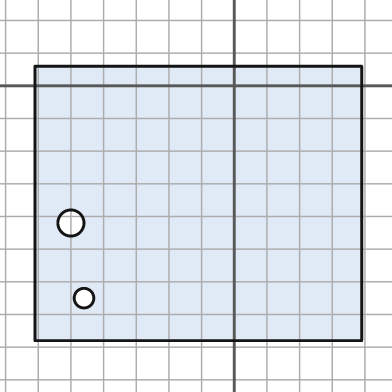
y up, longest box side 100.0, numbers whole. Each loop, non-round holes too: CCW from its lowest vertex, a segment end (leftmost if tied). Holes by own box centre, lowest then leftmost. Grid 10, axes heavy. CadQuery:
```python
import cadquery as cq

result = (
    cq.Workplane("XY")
    .moveTo(-61.0, -78.0)
    .lineTo(39.0, -78.0)
    .lineTo(39.0, 6.0)
    .lineTo(-61.0, 6.0)
    .close()
    .moveTo(-46.0, -65.0)
    .circle(3.0)
    .moveTo(-50.0, -42.0)
    .circle(4.0)
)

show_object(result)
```